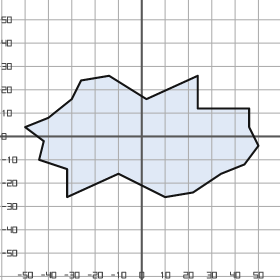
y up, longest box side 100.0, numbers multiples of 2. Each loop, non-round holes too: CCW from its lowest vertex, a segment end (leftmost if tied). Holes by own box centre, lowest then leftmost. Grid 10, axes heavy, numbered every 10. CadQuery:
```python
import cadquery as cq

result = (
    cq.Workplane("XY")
    .moveTo(-32.0, -26.0)
    .lineTo(-10.0, -16.0)
    .lineTo(10.0, -26.0)
    .lineTo(22.0, -24.0)
    .lineTo(34.0, -16.0)
    .lineTo(44.0, -12.0)
    .lineTo(50.0, -4.0)
    .lineTo(46.0, 4.0)
    .lineTo(46.0, 12.0)
    .lineTo(24.0, 12.0)
    .lineTo(24.0, 26.0)
    .lineTo(2.0, 16.0)
    .lineTo(-14.0, 26.0)
    .lineTo(-26.0, 24.0)
    .lineTo(-30.0, 16.0)
    .lineTo(-40.0, 8.0)
    .lineTo(-50.0, 4.0)
    .lineTo(-42.0, -2.0)
    .lineTo(-44.0, -10.0)
    .lineTo(-32.0, -14.0)
    .close()
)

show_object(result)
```